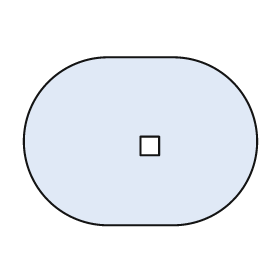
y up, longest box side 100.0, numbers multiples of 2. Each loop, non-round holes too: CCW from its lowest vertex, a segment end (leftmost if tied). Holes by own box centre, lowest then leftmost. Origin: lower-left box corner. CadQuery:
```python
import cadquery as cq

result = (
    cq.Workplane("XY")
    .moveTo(36.0, 0.0)
    .lineTo(64.0, 0.0)
    .threePointArc((100.0, 36.0), (64.0, 72.0))
    .lineTo(36.0, 72.0)
    .threePointArc((0.0, 36.0), (36.0, 0.0))
    .close()
    .moveTo(50.0, 30.0)
    .lineTo(58.0, 30.0)
    .lineTo(58.0, 38.0)
    .lineTo(50.0, 38.0)
    .close()
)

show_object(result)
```